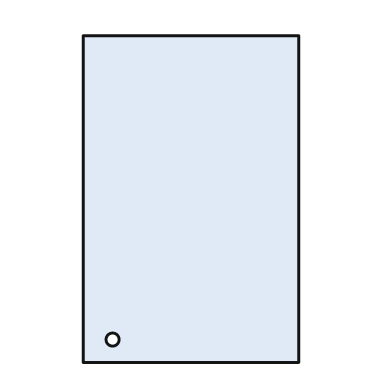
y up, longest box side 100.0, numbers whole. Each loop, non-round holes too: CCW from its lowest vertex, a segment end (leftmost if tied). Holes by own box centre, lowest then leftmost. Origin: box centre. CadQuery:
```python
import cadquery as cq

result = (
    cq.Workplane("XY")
    .moveTo(-33.0, -50.0)
    .lineTo(33.0, -50.0)
    .lineTo(33.0, 50.0)
    .lineTo(-33.0, 50.0)
    .close()
    .moveTo(-24.0, -43.0)
    .circle(2.0)
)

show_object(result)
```